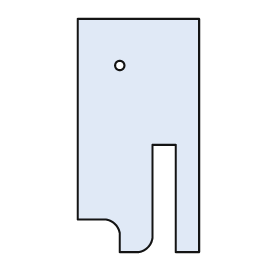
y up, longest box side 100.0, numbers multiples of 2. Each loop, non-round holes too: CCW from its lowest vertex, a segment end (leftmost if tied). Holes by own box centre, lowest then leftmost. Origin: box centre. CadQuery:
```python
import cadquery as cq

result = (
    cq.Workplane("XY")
    .moveTo(-8.0, -50.0)
    .lineTo(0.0, -50.0)
    .threePointArc((4.0, -48.0), (6.0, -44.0))
    .lineTo(6.0, -4.0)
    .lineTo(16.0, -4.0)
    .lineTo(16.0, -50.0)
    .lineTo(26.0, -50.0)
    .lineTo(26.0, 50.0)
    .lineTo(-26.0, 50.0)
    .lineTo(-26.0, -36.0)
    .lineTo(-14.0, -36.0)
    .threePointArc((-10.0, -38.0), (-8.0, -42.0))
    .close()
    .moveTo(-8.0, 30.0)
    .circle(2.0)
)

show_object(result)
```